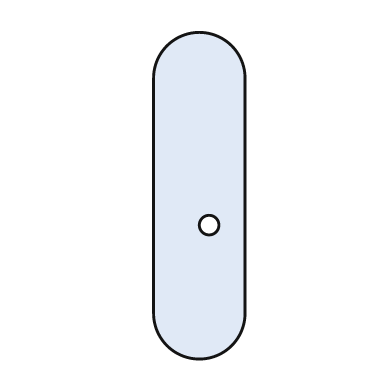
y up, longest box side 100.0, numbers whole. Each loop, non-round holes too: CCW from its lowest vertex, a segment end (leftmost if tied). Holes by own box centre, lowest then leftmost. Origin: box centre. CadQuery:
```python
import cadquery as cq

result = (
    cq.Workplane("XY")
    .moveTo(-14.0, -36.0)
    .threePointArc((0.0, -50.0), (14.0, -36.0))
    .lineTo(14.0, 36.0)
    .threePointArc((0.0, 50.0), (-14.0, 36.0))
    .close()
    .moveTo(3.0, -9.0)
    .circle(3.0)
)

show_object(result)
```